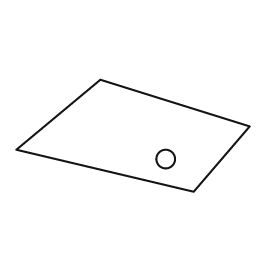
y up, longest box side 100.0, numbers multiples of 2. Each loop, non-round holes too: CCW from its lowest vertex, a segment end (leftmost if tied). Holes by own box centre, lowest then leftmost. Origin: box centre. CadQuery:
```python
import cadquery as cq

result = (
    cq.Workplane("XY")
    .moveTo(26.0, -24.0)
    .lineTo(50.0, 4.0)
    .lineTo(-14.0, 24.0)
    .lineTo(-50.0, -6.0)
    .close()
    .moveTo(14.0, -10.0)
    .circle(4.0)
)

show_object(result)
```